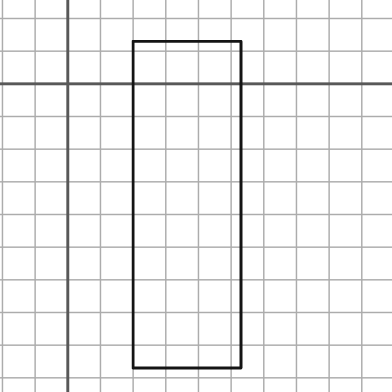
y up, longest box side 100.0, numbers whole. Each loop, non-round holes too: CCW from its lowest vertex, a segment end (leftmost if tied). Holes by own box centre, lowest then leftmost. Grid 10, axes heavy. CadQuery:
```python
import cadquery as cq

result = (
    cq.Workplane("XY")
    .moveTo(20.0, -87.0)
    .lineTo(53.0, -87.0)
    .lineTo(53.0, 13.0)
    .lineTo(20.0, 13.0)
    .close()
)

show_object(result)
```